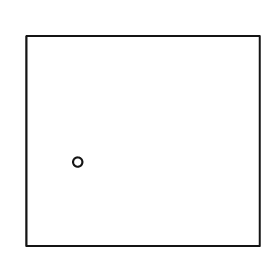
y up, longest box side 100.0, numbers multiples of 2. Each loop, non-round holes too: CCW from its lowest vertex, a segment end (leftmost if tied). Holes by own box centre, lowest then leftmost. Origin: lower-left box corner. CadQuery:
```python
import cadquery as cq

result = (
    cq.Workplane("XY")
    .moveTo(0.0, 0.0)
    .lineTo(100.0, 0.0)
    .lineTo(100.0, 90.0)
    .lineTo(0.0, 90.0)
    .close()
    .moveTo(22.0, 36.0)
    .circle(2.0)
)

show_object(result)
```